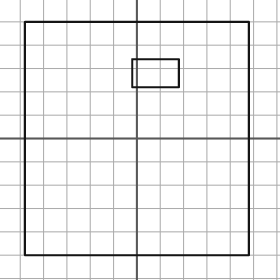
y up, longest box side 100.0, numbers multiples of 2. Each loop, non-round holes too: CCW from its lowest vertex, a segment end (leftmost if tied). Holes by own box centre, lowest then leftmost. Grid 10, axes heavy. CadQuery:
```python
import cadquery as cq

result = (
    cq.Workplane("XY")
    .moveTo(-48.0, -50.0)
    .lineTo(48.0, -50.0)
    .lineTo(48.0, 50.0)
    .lineTo(-48.0, 50.0)
    .close()
    .moveTo(-2.0, 22.0)
    .lineTo(18.0, 22.0)
    .lineTo(18.0, 34.0)
    .lineTo(-2.0, 34.0)
    .close()
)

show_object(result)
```